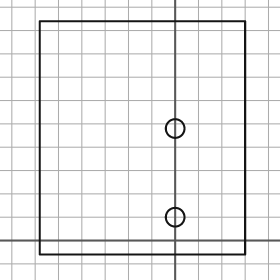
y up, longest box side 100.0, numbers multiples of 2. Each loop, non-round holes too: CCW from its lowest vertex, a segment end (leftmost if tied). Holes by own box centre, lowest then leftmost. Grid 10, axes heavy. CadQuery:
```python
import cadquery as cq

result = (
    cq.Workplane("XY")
    .moveTo(-58.0, -6.0)
    .lineTo(30.0, -6.0)
    .lineTo(30.0, 94.0)
    .lineTo(-58.0, 94.0)
    .close()
    .moveTo(0.0, 10.0)
    .circle(4.0)
    .moveTo(0.0, 48.0)
    .circle(4.0)
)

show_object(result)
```